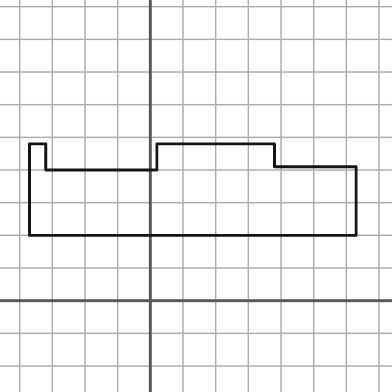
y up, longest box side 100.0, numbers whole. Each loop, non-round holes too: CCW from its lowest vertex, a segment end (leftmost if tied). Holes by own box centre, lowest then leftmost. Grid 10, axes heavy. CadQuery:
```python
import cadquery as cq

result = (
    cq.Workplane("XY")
    .moveTo(-37.0, 20.0)
    .lineTo(63.0, 20.0)
    .lineTo(63.0, 41.0)
    .lineTo(38.0, 41.0)
    .lineTo(38.0, 48.0)
    .lineTo(2.0, 48.0)
    .lineTo(2.0, 40.0)
    .lineTo(-32.0, 40.0)
    .lineTo(-32.0, 48.0)
    .lineTo(-37.0, 48.0)
    .close()
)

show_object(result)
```